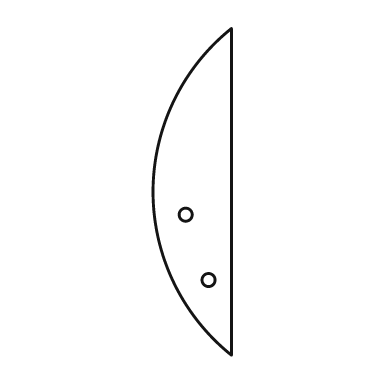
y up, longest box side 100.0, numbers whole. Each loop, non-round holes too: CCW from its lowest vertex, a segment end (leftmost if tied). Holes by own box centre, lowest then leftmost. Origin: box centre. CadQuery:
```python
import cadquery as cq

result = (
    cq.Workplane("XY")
    .moveTo(12.0, -50.0)
    .lineTo(12.0, 50.0)
    .threePointArc((-12.0, 0.0), (12.0, -50.0))
    .close()
    .moveTo(5.0, -27.0)
    .circle(2.0)
    .moveTo(-2.0, -7.0)
    .circle(2.0)
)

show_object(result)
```